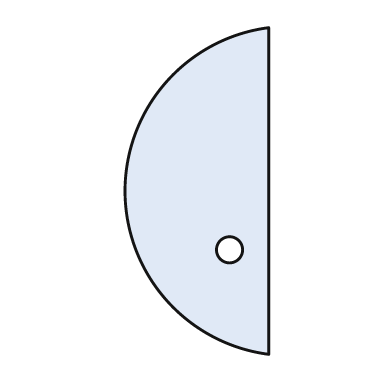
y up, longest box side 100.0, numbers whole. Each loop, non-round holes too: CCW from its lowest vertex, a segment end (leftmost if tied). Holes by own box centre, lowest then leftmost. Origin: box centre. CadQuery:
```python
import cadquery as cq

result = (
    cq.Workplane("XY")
    .moveTo(22.0, -50.0)
    .lineTo(22.0, 50.0)
    .threePointArc((-22.0, 0.0), (22.0, -50.0))
    .close()
    .moveTo(10.0, -18.0)
    .circle(4.0)
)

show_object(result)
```